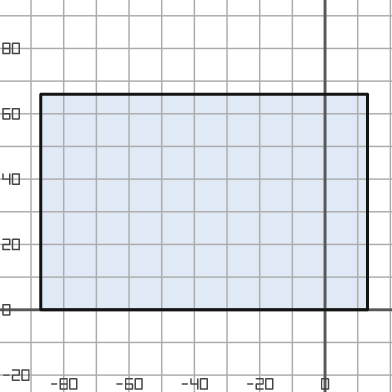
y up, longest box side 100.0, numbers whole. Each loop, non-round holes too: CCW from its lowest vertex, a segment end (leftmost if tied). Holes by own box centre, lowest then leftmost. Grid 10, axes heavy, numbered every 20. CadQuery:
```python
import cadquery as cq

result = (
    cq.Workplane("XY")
    .moveTo(-87.0, 0.0)
    .lineTo(13.0, 0.0)
    .lineTo(13.0, 66.0)
    .lineTo(-87.0, 66.0)
    .close()
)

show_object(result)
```